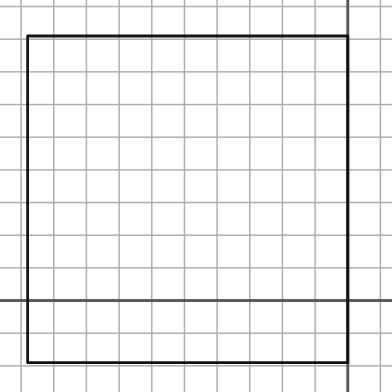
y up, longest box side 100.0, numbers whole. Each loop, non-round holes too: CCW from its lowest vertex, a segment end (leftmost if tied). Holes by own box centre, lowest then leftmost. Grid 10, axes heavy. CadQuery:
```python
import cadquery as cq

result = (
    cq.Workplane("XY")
    .moveTo(-98.0, -19.0)
    .lineTo(0.0, -19.0)
    .lineTo(0.0, 81.0)
    .lineTo(-98.0, 81.0)
    .close()
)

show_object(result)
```